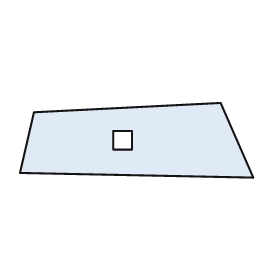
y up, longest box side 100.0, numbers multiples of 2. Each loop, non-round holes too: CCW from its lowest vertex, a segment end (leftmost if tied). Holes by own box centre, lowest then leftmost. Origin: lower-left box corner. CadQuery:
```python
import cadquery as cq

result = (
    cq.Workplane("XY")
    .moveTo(100.0, 0.0)
    .lineTo(86.0, 32.0)
    .lineTo(6.0, 28.0)
    .lineTo(0.0, 2.0)
    .close()
    .moveTo(40.0, 12.0)
    .lineTo(48.0, 12.0)
    .lineTo(48.0, 20.0)
    .lineTo(40.0, 20.0)
    .close()
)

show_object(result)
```